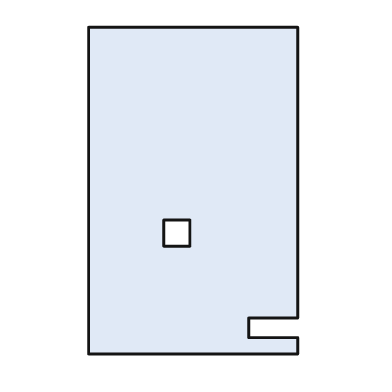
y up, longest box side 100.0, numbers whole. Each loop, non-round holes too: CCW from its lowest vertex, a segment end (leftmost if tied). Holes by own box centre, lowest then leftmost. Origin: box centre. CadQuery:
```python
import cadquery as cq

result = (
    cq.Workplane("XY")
    .moveTo(-32.0, -50.0)
    .lineTo(32.0, -50.0)
    .lineTo(32.0, -45.0)
    .lineTo(17.0, -45.0)
    .lineTo(17.0, -39.0)
    .lineTo(32.0, -39.0)
    .lineTo(32.0, 50.0)
    .lineTo(-32.0, 50.0)
    .close()
    .moveTo(-9.0, -17.0)
    .lineTo(-1.0, -17.0)
    .lineTo(-1.0, -9.0)
    .lineTo(-9.0, -9.0)
    .close()
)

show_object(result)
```